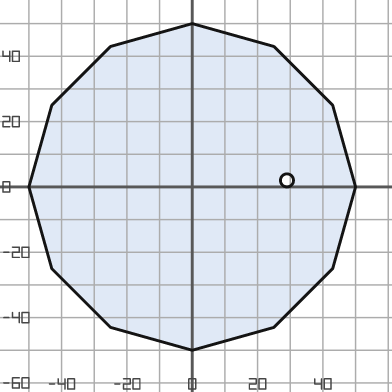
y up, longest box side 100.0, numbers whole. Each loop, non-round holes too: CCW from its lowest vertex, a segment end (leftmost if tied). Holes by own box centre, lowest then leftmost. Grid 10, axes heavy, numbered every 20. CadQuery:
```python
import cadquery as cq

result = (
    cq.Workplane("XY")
    .moveTo(0.0, -50.0)
    .lineTo(25.0, -43.0)
    .lineTo(43.0, -25.0)
    .lineTo(50.0, 0.0)
    .lineTo(43.0, 25.0)
    .lineTo(25.0, 43.0)
    .lineTo(0.0, 50.0)
    .lineTo(-25.0, 43.0)
    .lineTo(-43.0, 25.0)
    .lineTo(-50.0, 0.0)
    .lineTo(-43.0, -25.0)
    .lineTo(-25.0, -43.0)
    .close()
    .moveTo(29.0, 2.0)
    .circle(2.0)
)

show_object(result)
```